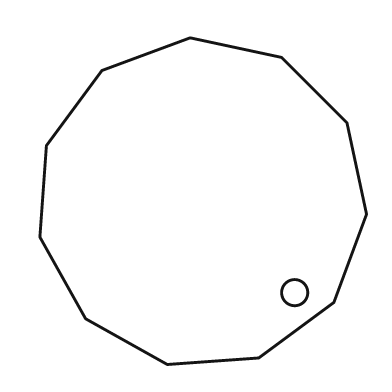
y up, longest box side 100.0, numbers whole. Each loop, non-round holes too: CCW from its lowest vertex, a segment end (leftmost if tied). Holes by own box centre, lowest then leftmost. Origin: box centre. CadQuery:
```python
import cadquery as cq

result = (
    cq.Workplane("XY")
    .moveTo(-11.0, -50.0)
    .lineTo(17.0, -48.0)
    .lineTo(40.0, -31.0)
    .lineTo(50.0, -4.0)
    .lineTo(44.0, 24.0)
    .lineTo(24.0, 44.0)
    .lineTo(-4.0, 50.0)
    .lineTo(-31.0, 40.0)
    .lineTo(-48.0, 17.0)
    .lineTo(-50.0, -11.0)
    .lineTo(-36.0, -36.0)
    .close()
    .moveTo(28.0, -28.0)
    .circle(4.0)
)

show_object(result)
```